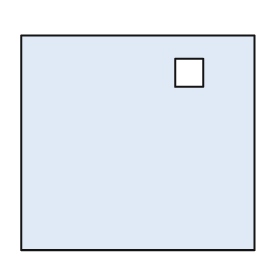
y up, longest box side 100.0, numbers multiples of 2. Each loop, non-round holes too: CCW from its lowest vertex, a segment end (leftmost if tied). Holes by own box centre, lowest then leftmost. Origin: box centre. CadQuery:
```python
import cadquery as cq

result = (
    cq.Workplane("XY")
    .moveTo(-50.0, -46.0)
    .lineTo(50.0, -46.0)
    .lineTo(50.0, 46.0)
    .lineTo(-50.0, 46.0)
    .close()
    .moveTo(16.0, 24.0)
    .lineTo(28.0, 24.0)
    .lineTo(28.0, 36.0)
    .lineTo(16.0, 36.0)
    .close()
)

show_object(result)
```